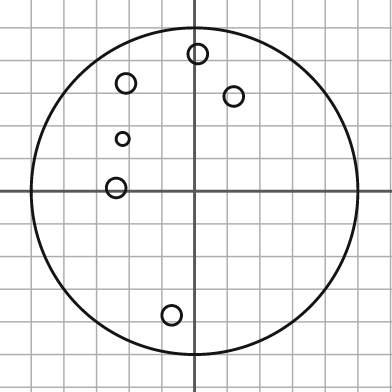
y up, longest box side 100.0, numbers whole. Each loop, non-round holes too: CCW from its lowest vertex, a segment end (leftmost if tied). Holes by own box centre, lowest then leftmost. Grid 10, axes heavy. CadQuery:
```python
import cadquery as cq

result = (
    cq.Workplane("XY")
    .moveTo(0.0, 0.0)
    .circle(50.0)
    .moveTo(-7.0, -38.0)
    .circle(3.0)
    .moveTo(-24.0, 1.0)
    .circle(3.0)
    .moveTo(-22.0, 16.0)
    .circle(2.0)
    .moveTo(12.0, 29.0)
    .circle(3.0)
    .moveTo(-21.0, 33.0)
    .circle(3.0)
    .moveTo(1.0, 42.0)
    .circle(3.0)
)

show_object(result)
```